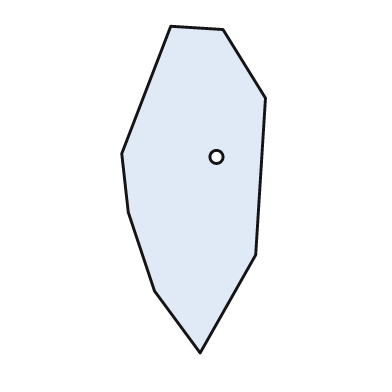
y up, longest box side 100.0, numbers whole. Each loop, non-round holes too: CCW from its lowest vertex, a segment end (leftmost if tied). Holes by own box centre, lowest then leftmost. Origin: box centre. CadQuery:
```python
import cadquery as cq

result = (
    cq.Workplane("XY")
    .moveTo(2.0, -50.0)
    .lineTo(19.0, -20.0)
    .lineTo(22.0, 28.0)
    .lineTo(9.0, 49.0)
    .lineTo(-7.0, 50.0)
    .lineTo(-22.0, 11.0)
    .lineTo(-20.0, -7.0)
    .lineTo(-12.0, -31.0)
    .close()
    .moveTo(7.0, 10.0)
    .circle(2.0)
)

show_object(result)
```